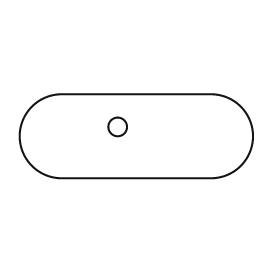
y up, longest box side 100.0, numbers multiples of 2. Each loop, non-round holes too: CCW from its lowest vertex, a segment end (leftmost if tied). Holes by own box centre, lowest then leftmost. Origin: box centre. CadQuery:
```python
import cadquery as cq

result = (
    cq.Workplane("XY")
    .moveTo(-32.0, -18.0)
    .lineTo(32.0, -18.0)
    .threePointArc((50.0, 0.0), (32.0, 18.0))
    .lineTo(-32.0, 18.0)
    .threePointArc((-50.0, 0.0), (-32.0, -18.0))
    .close()
    .moveTo(-8.0, 4.0)
    .circle(4.0)
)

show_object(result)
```